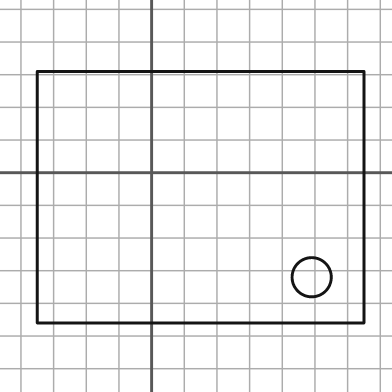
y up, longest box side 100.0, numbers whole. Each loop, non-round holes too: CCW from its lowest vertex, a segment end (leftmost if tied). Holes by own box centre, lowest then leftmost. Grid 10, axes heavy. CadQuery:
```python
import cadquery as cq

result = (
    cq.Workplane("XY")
    .moveTo(-35.0, -46.0)
    .lineTo(65.0, -46.0)
    .lineTo(65.0, 31.0)
    .lineTo(-35.0, 31.0)
    .close()
    .moveTo(49.0, -32.0)
    .circle(6.0)
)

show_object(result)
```